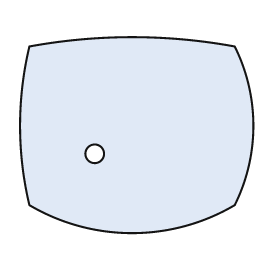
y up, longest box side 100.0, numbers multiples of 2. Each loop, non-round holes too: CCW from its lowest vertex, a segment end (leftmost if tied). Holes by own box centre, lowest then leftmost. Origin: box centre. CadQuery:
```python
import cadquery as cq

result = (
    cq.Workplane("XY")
    .moveTo(-46.0, -30.0)
    .threePointArc((-2.0, -42.0), (42.0, -30.0))
    .threePointArc((50.0, 4.0), (42.0, 38.0))
    .threePointArc((-2.0, 42.0), (-46.0, 38.0))
    .threePointArc((-50.0, 4.0), (-46.0, -30.0))
    .close()
    .moveTo(-18.0, -8.0)
    .circle(4.0)
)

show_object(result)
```